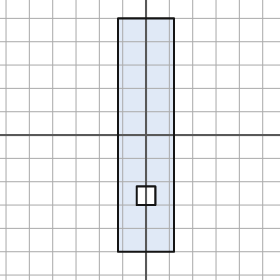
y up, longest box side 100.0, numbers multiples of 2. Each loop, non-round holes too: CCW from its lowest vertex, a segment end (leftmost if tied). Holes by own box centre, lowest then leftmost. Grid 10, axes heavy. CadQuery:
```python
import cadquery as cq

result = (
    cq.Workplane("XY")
    .moveTo(-12.0, -50.0)
    .lineTo(12.0, -50.0)
    .lineTo(12.0, 50.0)
    .lineTo(-12.0, 50.0)
    .close()
    .moveTo(-4.0, -30.0)
    .lineTo(4.0, -30.0)
    .lineTo(4.0, -22.0)
    .lineTo(-4.0, -22.0)
    .close()
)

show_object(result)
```